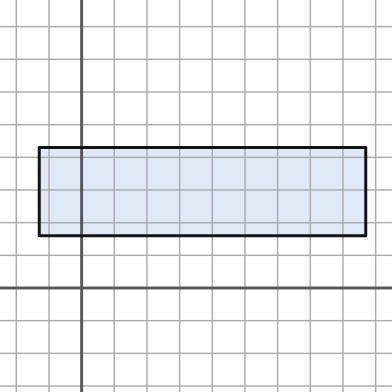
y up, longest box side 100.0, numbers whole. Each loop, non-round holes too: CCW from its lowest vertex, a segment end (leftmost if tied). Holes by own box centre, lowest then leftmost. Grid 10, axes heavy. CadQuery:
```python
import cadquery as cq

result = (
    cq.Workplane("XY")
    .moveTo(-13.0, 16.0)
    .lineTo(87.0, 16.0)
    .lineTo(87.0, 43.0)
    .lineTo(-13.0, 43.0)
    .close()
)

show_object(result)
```